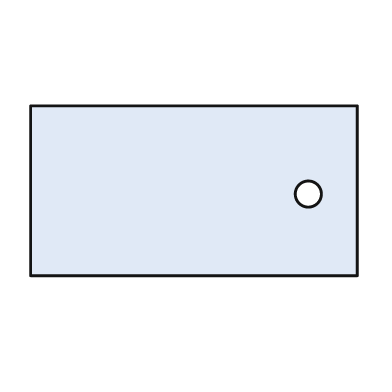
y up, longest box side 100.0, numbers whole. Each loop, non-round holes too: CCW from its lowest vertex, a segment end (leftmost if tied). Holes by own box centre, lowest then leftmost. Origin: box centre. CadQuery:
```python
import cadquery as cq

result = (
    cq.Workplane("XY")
    .moveTo(-50.0, -26.0)
    .lineTo(50.0, -26.0)
    .lineTo(50.0, 26.0)
    .lineTo(-50.0, 26.0)
    .close()
    .moveTo(35.0, -1.0)
    .circle(4.0)
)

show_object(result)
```